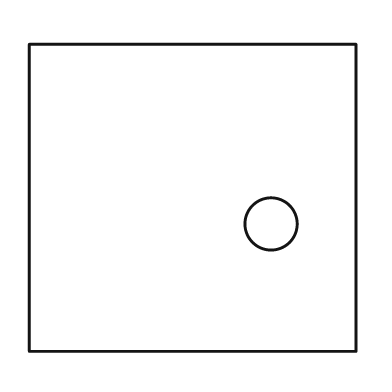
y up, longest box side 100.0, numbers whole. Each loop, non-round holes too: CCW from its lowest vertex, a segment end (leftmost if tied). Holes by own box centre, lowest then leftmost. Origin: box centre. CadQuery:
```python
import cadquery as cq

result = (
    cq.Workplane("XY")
    .moveTo(-50.0, -47.0)
    .lineTo(50.0, -47.0)
    .lineTo(50.0, 47.0)
    .lineTo(-50.0, 47.0)
    .close()
    .moveTo(24.0, -8.0)
    .circle(8.0)
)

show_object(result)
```